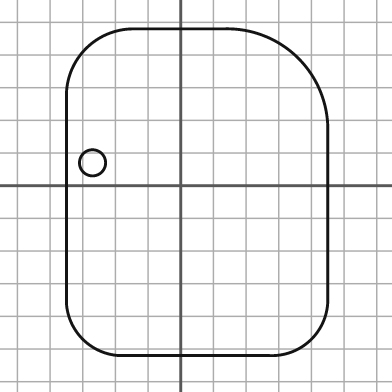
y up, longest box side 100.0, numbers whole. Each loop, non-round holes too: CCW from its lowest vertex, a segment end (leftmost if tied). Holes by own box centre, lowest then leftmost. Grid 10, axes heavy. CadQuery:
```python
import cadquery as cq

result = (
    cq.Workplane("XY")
    .moveTo(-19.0, -52.0)
    .lineTo(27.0, -52.0)
    .threePointArc((40.0, -47.0), (45.0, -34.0))
    .lineTo(45.0, 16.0)
    .threePointArc((36.0, 39.0), (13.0, 48.0))
    .lineTo(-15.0, 48.0)
    .threePointArc((-29.0, 42.0), (-35.0, 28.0))
    .lineTo(-35.0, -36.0)
    .threePointArc((-30.0, -47.0), (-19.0, -52.0))
    .close()
    .moveTo(-27.0, 7.0)
    .circle(4.0)
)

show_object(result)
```